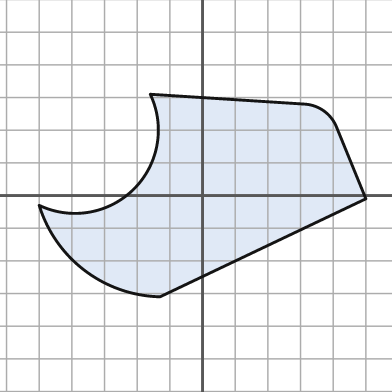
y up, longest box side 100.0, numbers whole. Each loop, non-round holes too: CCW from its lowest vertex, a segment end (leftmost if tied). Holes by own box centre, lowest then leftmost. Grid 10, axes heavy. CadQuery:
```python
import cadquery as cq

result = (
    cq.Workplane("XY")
    .moveTo(-13.0, -31.0)
    .lineTo(50.0, -1.0)
    .lineTo(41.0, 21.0)
    .threePointArc((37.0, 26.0), (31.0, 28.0))
    .lineTo(-16.0, 31.0)
    .threePointArc((-21.0, 2.0), (-50.0, -3.0))
    .threePointArc((-36.0, -23.0), (-13.0, -31.0))
    .close()
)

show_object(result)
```